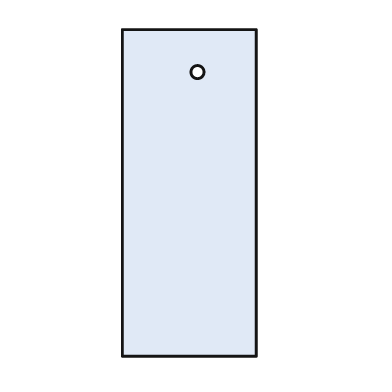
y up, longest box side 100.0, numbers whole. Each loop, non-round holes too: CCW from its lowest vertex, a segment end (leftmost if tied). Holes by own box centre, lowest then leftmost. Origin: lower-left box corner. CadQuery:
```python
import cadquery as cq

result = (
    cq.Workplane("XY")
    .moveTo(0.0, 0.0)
    .lineTo(41.0, 0.0)
    .lineTo(41.0, 100.0)
    .lineTo(0.0, 100.0)
    .close()
    .moveTo(23.0, 87.0)
    .circle(2.0)
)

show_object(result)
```